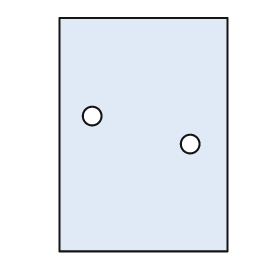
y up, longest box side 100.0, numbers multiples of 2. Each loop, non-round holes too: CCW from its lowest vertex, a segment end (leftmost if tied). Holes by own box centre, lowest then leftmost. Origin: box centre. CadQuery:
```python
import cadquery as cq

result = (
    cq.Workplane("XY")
    .moveTo(-36.0, -50.0)
    .lineTo(36.0, -50.0)
    .lineTo(36.0, 50.0)
    .lineTo(-36.0, 50.0)
    .close()
    .moveTo(20.0, -4.0)
    .circle(4.0)
    .moveTo(-22.0, 8.0)
    .circle(4.0)
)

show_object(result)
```